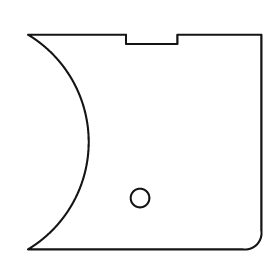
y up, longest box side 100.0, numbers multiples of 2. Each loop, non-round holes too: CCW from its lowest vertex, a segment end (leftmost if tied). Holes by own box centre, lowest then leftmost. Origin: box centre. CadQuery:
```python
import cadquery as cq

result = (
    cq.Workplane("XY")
    .moveTo(-50.0, -46.0)
    .lineTo(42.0, -46.0)
    .threePointArc((48.0, -44.0), (50.0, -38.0))
    .lineTo(50.0, 46.0)
    .lineTo(14.0, 46.0)
    .lineTo(14.0, 42.0)
    .lineTo(-8.0, 42.0)
    .lineTo(-8.0, 46.0)
    .lineTo(-50.0, 46.0)
    .threePointArc((-24.0, 0.0), (-50.0, -46.0))
    .close()
    .moveTo(-2.0, -24.0)
    .circle(4.0)
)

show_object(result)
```